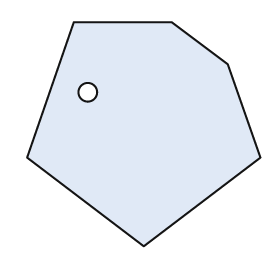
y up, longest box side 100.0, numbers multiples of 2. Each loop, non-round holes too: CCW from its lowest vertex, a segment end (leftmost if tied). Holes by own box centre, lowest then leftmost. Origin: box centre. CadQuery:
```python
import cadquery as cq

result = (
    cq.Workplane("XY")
    .moveTo(0.0, -48.0)
    .lineTo(50.0, -10.0)
    .lineTo(36.0, 30.0)
    .lineTo(12.0, 48.0)
    .lineTo(-30.0, 48.0)
    .lineTo(-50.0, -10.0)
    .close()
    .moveTo(-24.0, 18.0)
    .circle(4.0)
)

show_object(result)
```